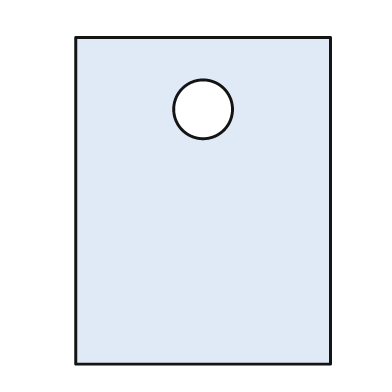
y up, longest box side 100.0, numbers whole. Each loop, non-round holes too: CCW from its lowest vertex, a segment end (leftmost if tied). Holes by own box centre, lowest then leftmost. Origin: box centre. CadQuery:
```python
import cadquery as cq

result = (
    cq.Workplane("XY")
    .moveTo(-39.0, -50.0)
    .lineTo(39.0, -50.0)
    .lineTo(39.0, 50.0)
    .lineTo(-39.0, 50.0)
    .close()
    .moveTo(0.0, 28.0)
    .circle(9.0)
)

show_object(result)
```